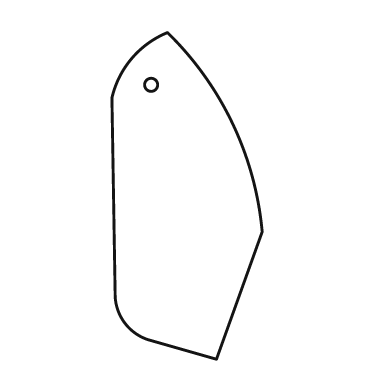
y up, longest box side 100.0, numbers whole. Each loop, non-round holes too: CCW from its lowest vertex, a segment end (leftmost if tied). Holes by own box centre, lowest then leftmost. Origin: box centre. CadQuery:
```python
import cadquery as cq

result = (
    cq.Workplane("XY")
    .moveTo(9.0, -50.0)
    .lineTo(23.0, -11.0)
    .threePointArc((14.0, 22.0), (-6.0, 50.0))
    .threePointArc((-17.0, 42.0), (-23.0, 30.0))
    .lineTo(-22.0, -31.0)
    .threePointArc((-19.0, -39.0), (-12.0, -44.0))
    .close()
    .moveTo(-11.0, 34.0)
    .circle(2.0)
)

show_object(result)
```